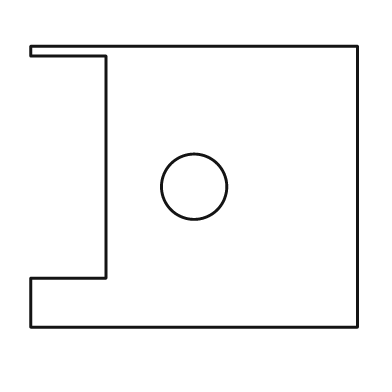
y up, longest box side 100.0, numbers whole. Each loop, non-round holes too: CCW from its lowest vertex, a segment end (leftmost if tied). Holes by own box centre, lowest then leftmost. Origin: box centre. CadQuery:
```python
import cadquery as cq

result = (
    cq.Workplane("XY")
    .moveTo(-50.0, -43.0)
    .lineTo(50.0, -43.0)
    .lineTo(50.0, 43.0)
    .lineTo(-50.0, 43.0)
    .lineTo(-50.0, 40.0)
    .lineTo(-27.0, 40.0)
    .lineTo(-27.0, -28.0)
    .lineTo(-50.0, -28.0)
    .close()
    .moveTo(0.0, 0.0)
    .circle(10.0)
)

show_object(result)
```